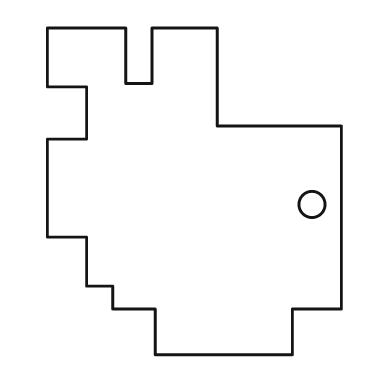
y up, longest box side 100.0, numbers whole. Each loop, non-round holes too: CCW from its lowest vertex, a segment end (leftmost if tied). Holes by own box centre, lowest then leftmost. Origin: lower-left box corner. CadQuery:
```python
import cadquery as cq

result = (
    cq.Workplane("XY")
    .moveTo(33.0, 0.0)
    .lineTo(75.0, 0.0)
    .lineTo(75.0, 14.0)
    .lineTo(90.0, 14.0)
    .lineTo(90.0, 70.0)
    .lineTo(52.0, 70.0)
    .lineTo(52.0, 100.0)
    .lineTo(32.0, 100.0)
    .lineTo(32.0, 83.0)
    .lineTo(24.0, 83.0)
    .lineTo(24.0, 100.0)
    .lineTo(0.0, 100.0)
    .lineTo(0.0, 82.0)
    .lineTo(12.0, 82.0)
    .lineTo(12.0, 66.0)
    .lineTo(0.0, 66.0)
    .lineTo(0.0, 36.0)
    .lineTo(12.0, 36.0)
    .lineTo(12.0, 21.0)
    .lineTo(20.0, 21.0)
    .lineTo(20.0, 14.0)
    .lineTo(33.0, 14.0)
    .close()
    .moveTo(81.0, 46.0)
    .circle(4.0)
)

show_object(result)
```